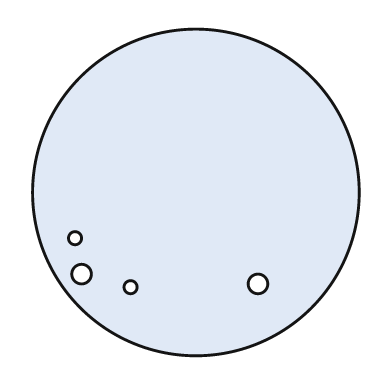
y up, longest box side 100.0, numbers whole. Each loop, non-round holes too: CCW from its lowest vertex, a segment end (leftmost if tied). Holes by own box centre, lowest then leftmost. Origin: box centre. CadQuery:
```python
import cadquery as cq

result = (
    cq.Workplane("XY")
    .moveTo(0.0, 0.0)
    .circle(50.0)
    .moveTo(-20.0, -29.0)
    .circle(2.0)
    .moveTo(19.0, -28.0)
    .circle(3.0)
    .moveTo(-35.0, -25.0)
    .circle(3.0)
    .moveTo(-37.0, -14.0)
    .circle(2.0)
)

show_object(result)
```